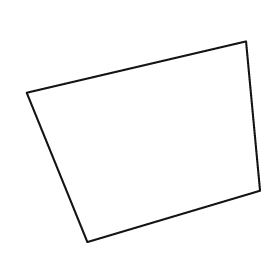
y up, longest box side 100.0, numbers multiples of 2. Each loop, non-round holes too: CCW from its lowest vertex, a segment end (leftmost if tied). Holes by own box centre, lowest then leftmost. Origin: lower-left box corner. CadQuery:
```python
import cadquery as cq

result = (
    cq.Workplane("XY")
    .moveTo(26.0, 0.0)
    .lineTo(100.0, 22.0)
    .lineTo(94.0, 86.0)
    .lineTo(0.0, 64.0)
    .close()
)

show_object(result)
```